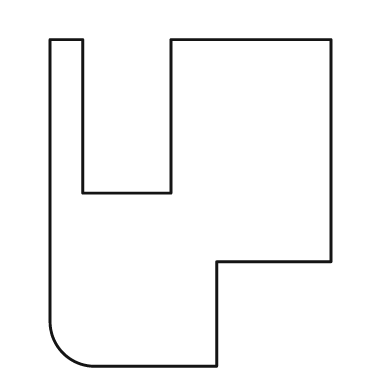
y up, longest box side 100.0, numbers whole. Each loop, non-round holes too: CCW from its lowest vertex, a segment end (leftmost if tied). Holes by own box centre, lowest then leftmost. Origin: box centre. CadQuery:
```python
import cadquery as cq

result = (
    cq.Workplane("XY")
    .moveTo(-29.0, -50.0)
    .lineTo(8.0, -50.0)
    .lineTo(8.0, -18.0)
    .lineTo(43.0, -18.0)
    .lineTo(43.0, 50.0)
    .lineTo(-6.0, 50.0)
    .lineTo(-6.0, 3.0)
    .lineTo(-33.0, 3.0)
    .lineTo(-33.0, 50.0)
    .lineTo(-43.0, 50.0)
    .lineTo(-43.0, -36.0)
    .threePointArc((-39.0, -46.0), (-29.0, -50.0))
    .close()
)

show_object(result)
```